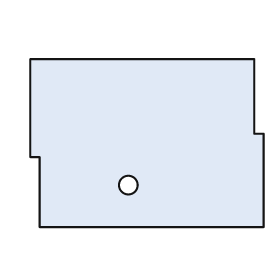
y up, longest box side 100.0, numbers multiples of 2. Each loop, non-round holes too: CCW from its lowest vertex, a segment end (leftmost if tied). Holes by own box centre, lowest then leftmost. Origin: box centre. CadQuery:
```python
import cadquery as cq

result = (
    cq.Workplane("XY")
    .moveTo(-46.0, -36.0)
    .lineTo(50.0, -36.0)
    .lineTo(50.0, 4.0)
    .lineTo(46.0, 4.0)
    .lineTo(46.0, 36.0)
    .lineTo(-50.0, 36.0)
    .lineTo(-50.0, -6.0)
    .lineTo(-46.0, -6.0)
    .close()
    .moveTo(-8.0, -18.0)
    .circle(4.0)
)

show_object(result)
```